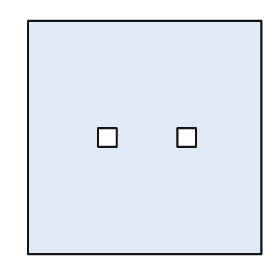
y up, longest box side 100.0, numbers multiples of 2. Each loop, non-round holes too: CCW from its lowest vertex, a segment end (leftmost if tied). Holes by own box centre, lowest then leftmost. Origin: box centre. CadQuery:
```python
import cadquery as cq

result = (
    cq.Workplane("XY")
    .moveTo(-50.0, -50.0)
    .lineTo(50.0, -50.0)
    .lineTo(50.0, 50.0)
    .lineTo(-50.0, 50.0)
    .close()
    .moveTo(-20.0, -4.0)
    .lineTo(-12.0, -4.0)
    .lineTo(-12.0, 4.0)
    .lineTo(-20.0, 4.0)
    .close()
    .moveTo(14.0, -4.0)
    .lineTo(22.0, -4.0)
    .lineTo(22.0, 4.0)
    .lineTo(14.0, 4.0)
    .close()
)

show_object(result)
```